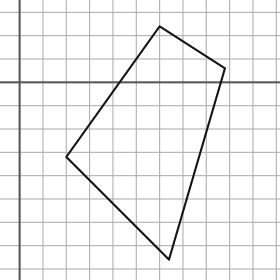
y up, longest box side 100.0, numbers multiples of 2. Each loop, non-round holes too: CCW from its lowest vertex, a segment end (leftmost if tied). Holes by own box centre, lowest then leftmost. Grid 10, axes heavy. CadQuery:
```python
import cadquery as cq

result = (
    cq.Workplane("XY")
    .moveTo(64.0, -76.0)
    .lineTo(88.0, 6.0)
    .lineTo(60.0, 24.0)
    .lineTo(20.0, -32.0)
    .close()
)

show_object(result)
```